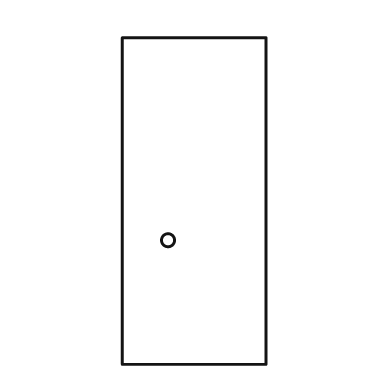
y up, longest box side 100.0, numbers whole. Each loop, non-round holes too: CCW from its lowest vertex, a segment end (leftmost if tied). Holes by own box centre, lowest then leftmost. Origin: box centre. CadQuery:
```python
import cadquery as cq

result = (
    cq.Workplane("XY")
    .moveTo(-22.0, -50.0)
    .lineTo(22.0, -50.0)
    .lineTo(22.0, 50.0)
    .lineTo(-22.0, 50.0)
    .close()
    .moveTo(-8.0, -12.0)
    .circle(2.0)
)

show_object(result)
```